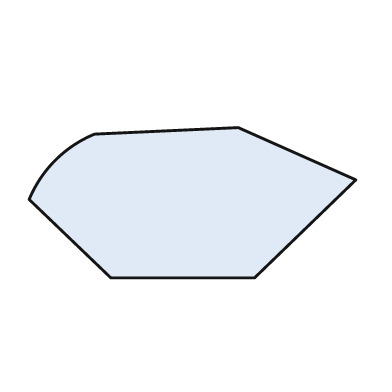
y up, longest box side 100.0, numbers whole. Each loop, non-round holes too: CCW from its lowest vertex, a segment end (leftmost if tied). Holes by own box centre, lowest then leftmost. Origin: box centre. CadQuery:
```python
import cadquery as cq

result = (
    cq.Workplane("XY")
    .moveTo(-25.0, -23.0)
    .lineTo(19.0, -23.0)
    .lineTo(50.0, 7.0)
    .lineTo(14.0, 23.0)
    .lineTo(-30.0, 21.0)
    .threePointArc((-42.0, 13.0), (-50.0, 1.0))
    .close()
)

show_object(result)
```